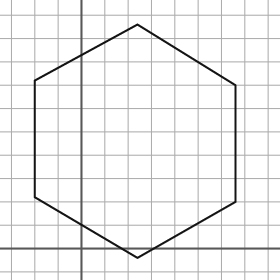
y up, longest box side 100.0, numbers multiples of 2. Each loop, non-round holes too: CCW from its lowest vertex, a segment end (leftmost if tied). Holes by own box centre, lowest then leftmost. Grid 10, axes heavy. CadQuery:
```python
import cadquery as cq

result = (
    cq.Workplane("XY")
    .moveTo(24.0, -4.0)
    .lineTo(66.0, 20.0)
    .lineTo(66.0, 70.0)
    .lineTo(24.0, 96.0)
    .lineTo(-20.0, 72.0)
    .lineTo(-20.0, 22.0)
    .close()
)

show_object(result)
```